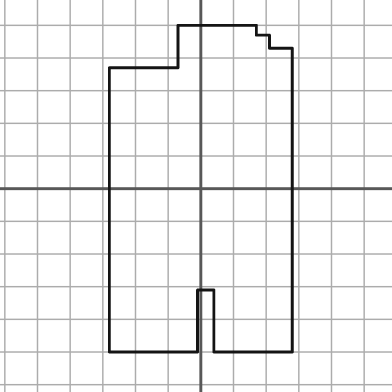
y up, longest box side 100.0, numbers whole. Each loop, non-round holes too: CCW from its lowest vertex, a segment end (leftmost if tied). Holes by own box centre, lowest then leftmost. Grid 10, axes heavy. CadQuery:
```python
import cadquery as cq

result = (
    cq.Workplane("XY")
    .moveTo(-28.0, -50.0)
    .lineTo(-1.0, -50.0)
    .lineTo(-1.0, -31.0)
    .lineTo(4.0, -31.0)
    .lineTo(4.0, -50.0)
    .lineTo(28.0, -50.0)
    .lineTo(28.0, 43.0)
    .lineTo(21.0, 43.0)
    .lineTo(21.0, 47.0)
    .lineTo(17.0, 47.0)
    .lineTo(17.0, 50.0)
    .lineTo(-7.0, 50.0)
    .lineTo(-7.0, 37.0)
    .lineTo(-28.0, 37.0)
    .close()
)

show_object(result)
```